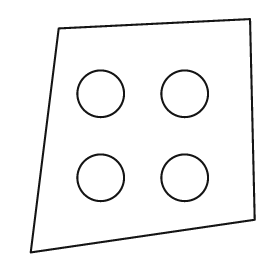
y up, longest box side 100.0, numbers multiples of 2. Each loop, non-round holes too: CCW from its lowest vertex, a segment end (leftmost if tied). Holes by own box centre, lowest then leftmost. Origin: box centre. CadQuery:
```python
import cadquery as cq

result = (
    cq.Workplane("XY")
    .moveTo(-48.0, -50.0)
    .lineTo(48.0, -36.0)
    .lineTo(46.0, 50.0)
    .lineTo(-36.0, 46.0)
    .close()
    .moveTo(-18.0, -18.0)
    .circle(10.0)
    .moveTo(18.0, -18.0)
    .circle(10.0)
    .moveTo(-18.0, 18.0)
    .circle(10.0)
    .moveTo(18.0, 18.0)
    .circle(10.0)
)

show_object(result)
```